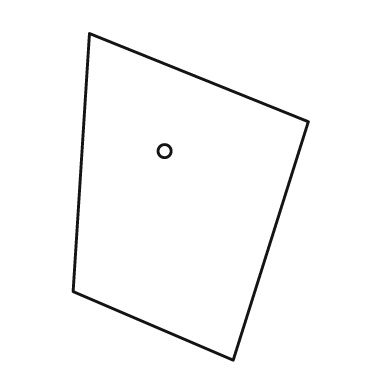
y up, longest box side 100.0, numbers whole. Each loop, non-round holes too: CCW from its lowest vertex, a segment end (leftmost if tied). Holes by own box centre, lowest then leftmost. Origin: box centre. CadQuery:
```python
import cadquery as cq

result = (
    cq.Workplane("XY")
    .moveTo(13.0, -50.0)
    .lineTo(36.0, 23.0)
    .lineTo(-31.0, 50.0)
    .lineTo(-36.0, -29.0)
    .close()
    .moveTo(-8.0, 14.0)
    .circle(2.0)
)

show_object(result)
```